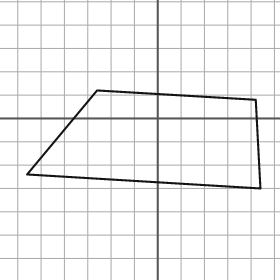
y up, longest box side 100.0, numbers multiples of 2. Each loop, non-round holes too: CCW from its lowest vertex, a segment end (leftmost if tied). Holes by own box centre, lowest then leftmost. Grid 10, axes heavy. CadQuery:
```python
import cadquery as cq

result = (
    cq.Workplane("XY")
    .moveTo(44.0, -30.0)
    .lineTo(42.0, 8.0)
    .lineTo(-26.0, 12.0)
    .lineTo(-56.0, -24.0)
    .close()
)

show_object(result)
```